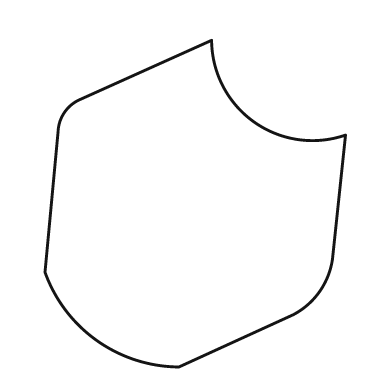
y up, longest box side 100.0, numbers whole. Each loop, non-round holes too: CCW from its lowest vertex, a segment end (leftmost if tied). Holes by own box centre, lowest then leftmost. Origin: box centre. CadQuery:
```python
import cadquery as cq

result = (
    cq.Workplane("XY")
    .moveTo(-5.0, -50.0)
    .lineTo(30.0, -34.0)
    .threePointArc((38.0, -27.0), (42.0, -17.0))
    .lineTo(46.0, 21.0)
    .threePointArc((18.0, 25.0), (5.0, 50.0))
    .lineTo(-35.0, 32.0)
    .threePointArc((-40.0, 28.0), (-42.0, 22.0))
    .lineTo(-46.0, -21.0)
    .threePointArc((-30.0, -42.0), (-5.0, -50.0))
    .close()
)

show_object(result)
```